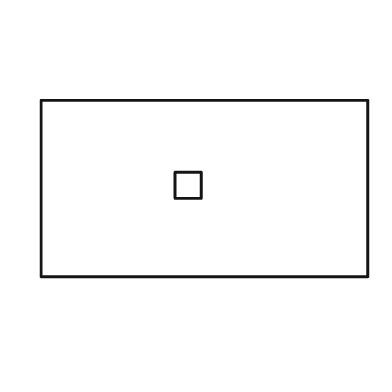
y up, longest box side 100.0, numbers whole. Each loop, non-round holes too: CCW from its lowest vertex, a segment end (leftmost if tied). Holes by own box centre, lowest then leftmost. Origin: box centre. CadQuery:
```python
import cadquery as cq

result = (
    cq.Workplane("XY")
    .moveTo(-50.0, -27.0)
    .lineTo(50.0, -27.0)
    .lineTo(50.0, 27.0)
    .lineTo(-50.0, 27.0)
    .close()
    .moveTo(-9.0, -3.0)
    .lineTo(-1.0, -3.0)
    .lineTo(-1.0, 5.0)
    .lineTo(-9.0, 5.0)
    .close()
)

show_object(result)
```